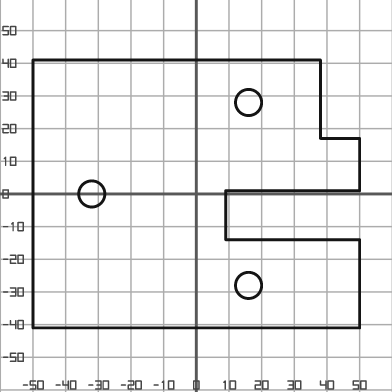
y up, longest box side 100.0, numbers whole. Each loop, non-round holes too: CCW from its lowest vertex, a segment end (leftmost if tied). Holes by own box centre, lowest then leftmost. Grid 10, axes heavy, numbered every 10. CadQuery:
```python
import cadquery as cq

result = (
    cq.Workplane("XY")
    .moveTo(-50.0, -41.0)
    .lineTo(50.0, -41.0)
    .lineTo(50.0, -14.0)
    .lineTo(9.0, -14.0)
    .lineTo(9.0, 1.0)
    .lineTo(50.0, 1.0)
    .lineTo(50.0, 17.0)
    .lineTo(38.0, 17.0)
    .lineTo(38.0, 41.0)
    .lineTo(-50.0, 41.0)
    .close()
    .moveTo(16.0, -28.0)
    .circle(4.0)
    .moveTo(-32.0, 0.0)
    .circle(4.0)
    .moveTo(16.0, 28.0)
    .circle(4.0)
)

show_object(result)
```